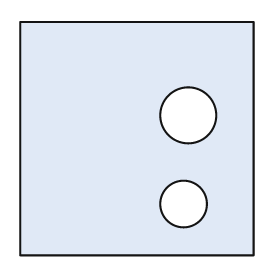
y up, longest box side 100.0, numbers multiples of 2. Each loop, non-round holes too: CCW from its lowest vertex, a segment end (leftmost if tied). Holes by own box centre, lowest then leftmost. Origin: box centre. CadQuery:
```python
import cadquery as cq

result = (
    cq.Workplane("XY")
    .moveTo(-50.0, -50.0)
    .lineTo(50.0, -50.0)
    .lineTo(50.0, 50.0)
    .lineTo(-50.0, 50.0)
    .close()
    .moveTo(20.0, -28.0)
    .circle(10.0)
    .moveTo(22.0, 10.0)
    .circle(12.0)
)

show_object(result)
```